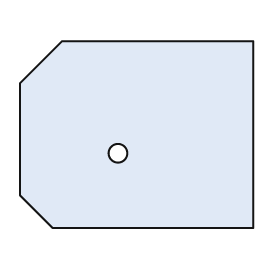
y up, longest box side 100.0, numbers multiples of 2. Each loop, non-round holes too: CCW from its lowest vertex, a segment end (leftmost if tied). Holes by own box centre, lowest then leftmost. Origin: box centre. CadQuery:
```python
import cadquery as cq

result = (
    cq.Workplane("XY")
    .moveTo(-36.0, -40.0)
    .lineTo(50.0, -40.0)
    .lineTo(50.0, 40.0)
    .lineTo(-32.0, 40.0)
    .lineTo(-50.0, 22.0)
    .lineTo(-50.0, -26.0)
    .close()
    .moveTo(-8.0, -8.0)
    .circle(4.0)
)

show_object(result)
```